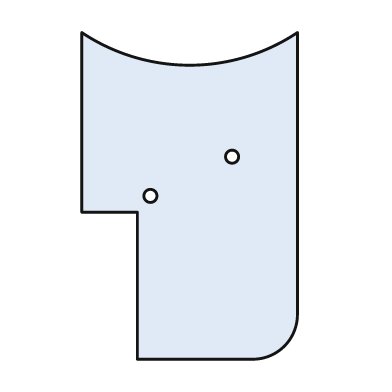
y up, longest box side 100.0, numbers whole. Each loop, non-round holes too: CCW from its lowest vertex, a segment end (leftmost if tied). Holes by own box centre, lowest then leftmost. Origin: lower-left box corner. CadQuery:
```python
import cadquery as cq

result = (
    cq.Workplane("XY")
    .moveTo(17.0, 0.0)
    .lineTo(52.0, 0.0)
    .threePointArc((62.0, 4.0), (66.0, 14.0))
    .lineTo(66.0, 100.0)
    .threePointArc((33.0, 90.0), (0.0, 100.0))
    .lineTo(0.0, 45.0)
    .lineTo(17.0, 45.0)
    .close()
    .moveTo(21.0, 50.0)
    .circle(2.0)
    .moveTo(46.0, 62.0)
    .circle(2.0)
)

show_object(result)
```